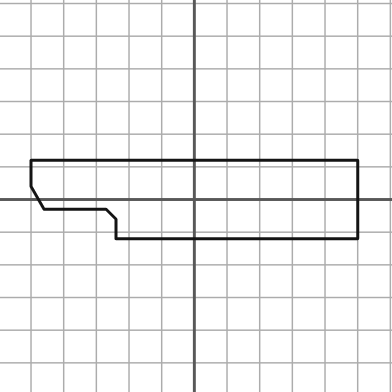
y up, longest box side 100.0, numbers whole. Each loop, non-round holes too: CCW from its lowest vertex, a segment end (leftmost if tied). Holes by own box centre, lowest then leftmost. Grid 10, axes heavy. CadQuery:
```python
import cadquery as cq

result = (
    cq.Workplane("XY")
    .moveTo(-24.0, -12.0)
    .lineTo(50.0, -12.0)
    .lineTo(50.0, 12.0)
    .lineTo(-50.0, 12.0)
    .lineTo(-50.0, 4.0)
    .lineTo(-46.0, -3.0)
    .lineTo(-27.0, -3.0)
    .lineTo(-24.0, -6.0)
    .close()
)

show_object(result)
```